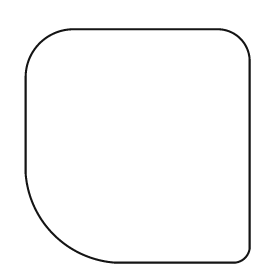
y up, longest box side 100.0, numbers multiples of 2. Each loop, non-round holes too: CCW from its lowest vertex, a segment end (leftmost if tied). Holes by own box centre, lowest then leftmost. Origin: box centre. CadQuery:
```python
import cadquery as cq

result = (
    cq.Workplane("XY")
    .moveTo(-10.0, -50.0)
    .lineTo(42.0, -50.0)
    .threePointArc((46.0, -48.0), (48.0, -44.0))
    .lineTo(48.0, 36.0)
    .threePointArc((44.0, 46.0), (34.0, 50.0))
    .lineTo(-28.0, 50.0)
    .threePointArc((-42.0, 44.0), (-48.0, 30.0))
    .lineTo(-48.0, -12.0)
    .threePointArc((-36.0, -38.0), (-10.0, -50.0))
    .close()
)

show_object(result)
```